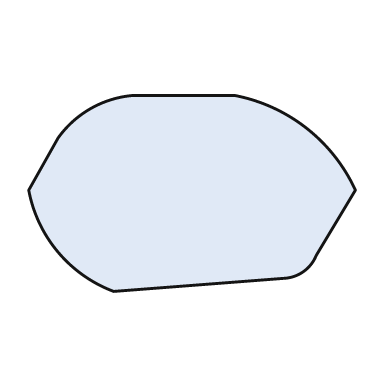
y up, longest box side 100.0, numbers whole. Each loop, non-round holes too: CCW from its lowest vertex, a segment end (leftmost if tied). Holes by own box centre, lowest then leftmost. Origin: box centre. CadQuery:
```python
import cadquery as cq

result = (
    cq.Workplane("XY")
    .moveTo(-24.0, -30.0)
    .lineTo(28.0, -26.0)
    .threePointArc((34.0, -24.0), (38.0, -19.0))
    .lineTo(50.0, 1.0)
    .threePointArc((35.0, 20.0), (13.0, 30.0))
    .lineTo(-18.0, 30.0)
    .threePointArc((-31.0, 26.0), (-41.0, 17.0))
    .lineTo(-50.0, 1.0)
    .threePointArc((-41.0, -18.0), (-24.0, -30.0))
    .close()
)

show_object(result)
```